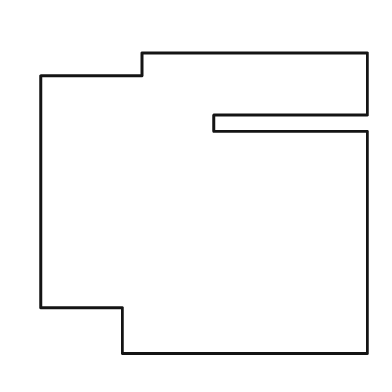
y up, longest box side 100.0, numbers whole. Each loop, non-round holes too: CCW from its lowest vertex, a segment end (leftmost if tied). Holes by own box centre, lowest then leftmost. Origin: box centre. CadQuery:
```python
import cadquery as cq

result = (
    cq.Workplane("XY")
    .moveTo(-25.0, -46.0)
    .lineTo(50.0, -46.0)
    .lineTo(50.0, 22.0)
    .lineTo(3.0, 22.0)
    .lineTo(3.0, 27.0)
    .lineTo(50.0, 27.0)
    .lineTo(50.0, 46.0)
    .lineTo(-19.0, 46.0)
    .lineTo(-19.0, 39.0)
    .lineTo(-50.0, 39.0)
    .lineTo(-50.0, -32.0)
    .lineTo(-25.0, -32.0)
    .close()
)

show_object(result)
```